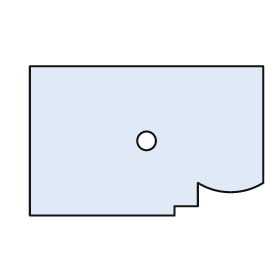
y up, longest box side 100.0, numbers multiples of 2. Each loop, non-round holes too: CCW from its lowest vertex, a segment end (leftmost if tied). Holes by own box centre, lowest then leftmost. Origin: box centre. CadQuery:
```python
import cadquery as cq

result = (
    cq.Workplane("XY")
    .moveTo(-50.0, -32.0)
    .lineTo(12.0, -32.0)
    .lineTo(12.0, -28.0)
    .lineTo(22.0, -28.0)
    .lineTo(22.0, -18.0)
    .threePointArc((36.0, -22.0), (50.0, -18.0))
    .lineTo(50.0, 32.0)
    .lineTo(-50.0, 32.0)
    .close()
    .moveTo(0.0, 0.0)
    .circle(4.0)
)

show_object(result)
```